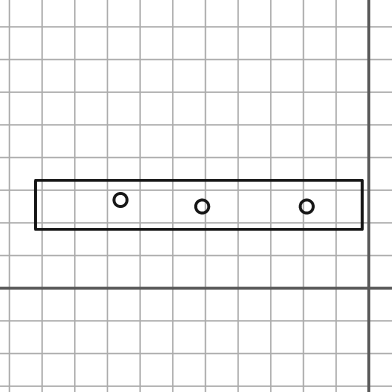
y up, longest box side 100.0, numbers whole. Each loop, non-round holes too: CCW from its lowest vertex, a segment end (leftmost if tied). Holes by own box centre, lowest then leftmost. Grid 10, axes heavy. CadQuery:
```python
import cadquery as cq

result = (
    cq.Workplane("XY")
    .moveTo(-102.0, 18.0)
    .lineTo(-2.0, 18.0)
    .lineTo(-2.0, 33.0)
    .lineTo(-102.0, 33.0)
    .close()
    .moveTo(-51.0, 25.0)
    .circle(2.0)
    .moveTo(-19.0, 25.0)
    .circle(2.0)
    .moveTo(-76.0, 27.0)
    .circle(2.0)
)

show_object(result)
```